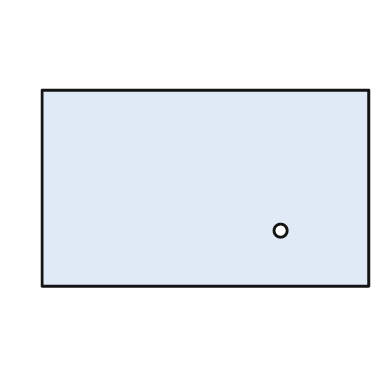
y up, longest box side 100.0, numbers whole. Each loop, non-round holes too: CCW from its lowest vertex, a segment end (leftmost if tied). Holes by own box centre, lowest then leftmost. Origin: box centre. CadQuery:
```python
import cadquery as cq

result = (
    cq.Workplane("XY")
    .moveTo(-50.0, -30.0)
    .lineTo(50.0, -30.0)
    .lineTo(50.0, 30.0)
    .lineTo(-50.0, 30.0)
    .close()
    .moveTo(23.0, -13.0)
    .circle(2.0)
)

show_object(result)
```